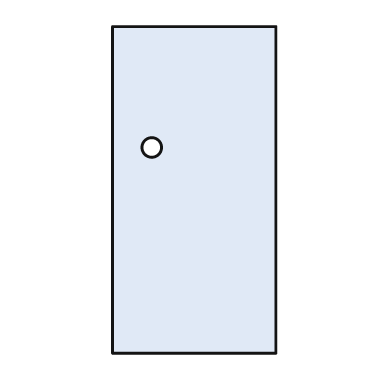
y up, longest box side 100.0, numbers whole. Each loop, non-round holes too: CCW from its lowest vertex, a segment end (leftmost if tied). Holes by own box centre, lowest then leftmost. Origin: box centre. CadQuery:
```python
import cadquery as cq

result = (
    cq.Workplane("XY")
    .moveTo(-25.0, -50.0)
    .lineTo(25.0, -50.0)
    .lineTo(25.0, 50.0)
    .lineTo(-25.0, 50.0)
    .close()
    .moveTo(-13.0, 13.0)
    .circle(3.0)
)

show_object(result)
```